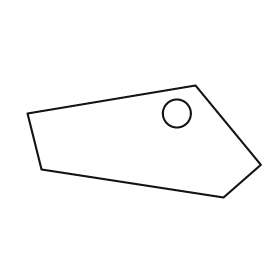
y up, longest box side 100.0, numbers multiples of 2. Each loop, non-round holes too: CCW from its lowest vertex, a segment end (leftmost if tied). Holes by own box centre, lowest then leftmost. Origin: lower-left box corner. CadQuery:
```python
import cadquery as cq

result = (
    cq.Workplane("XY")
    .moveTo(84.0, 0.0)
    .lineTo(100.0, 14.0)
    .lineTo(72.0, 48.0)
    .lineTo(0.0, 36.0)
    .lineTo(6.0, 12.0)
    .close()
    .moveTo(64.0, 36.0)
    .circle(6.0)
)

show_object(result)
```